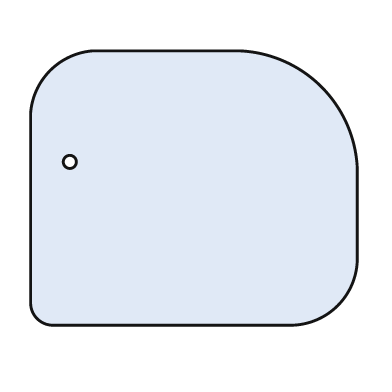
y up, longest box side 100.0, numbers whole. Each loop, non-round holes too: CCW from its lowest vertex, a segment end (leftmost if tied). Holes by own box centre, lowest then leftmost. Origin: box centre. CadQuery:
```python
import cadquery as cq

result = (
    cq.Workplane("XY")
    .moveTo(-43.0, -42.0)
    .lineTo(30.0, -42.0)
    .threePointArc((44.0, -36.0), (50.0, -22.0))
    .lineTo(50.0, 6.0)
    .threePointArc((39.0, 31.0), (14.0, 42.0))
    .lineTo(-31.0, 42.0)
    .threePointArc((-44.0, 36.0), (-50.0, 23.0))
    .lineTo(-50.0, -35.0)
    .threePointArc((-48.0, -40.0), (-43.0, -42.0))
    .close()
    .moveTo(-38.0, 8.0)
    .circle(2.0)
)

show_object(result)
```